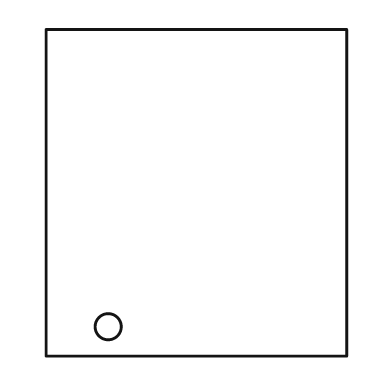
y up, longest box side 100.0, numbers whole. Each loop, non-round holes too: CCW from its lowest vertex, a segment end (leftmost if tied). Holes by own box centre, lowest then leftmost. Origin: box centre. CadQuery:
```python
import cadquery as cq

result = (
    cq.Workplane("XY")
    .moveTo(-46.0, -50.0)
    .lineTo(46.0, -50.0)
    .lineTo(46.0, 50.0)
    .lineTo(-46.0, 50.0)
    .close()
    .moveTo(-27.0, -41.0)
    .circle(4.0)
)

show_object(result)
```